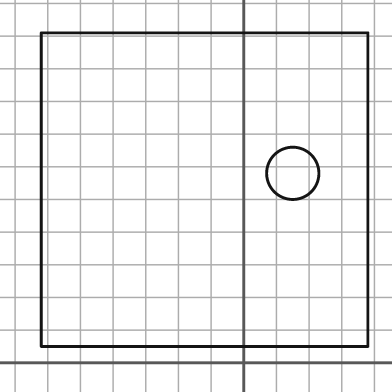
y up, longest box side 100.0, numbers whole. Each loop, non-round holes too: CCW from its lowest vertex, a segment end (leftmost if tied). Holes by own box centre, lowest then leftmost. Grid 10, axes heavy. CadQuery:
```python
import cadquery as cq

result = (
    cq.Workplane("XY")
    .moveTo(-62.0, 5.0)
    .lineTo(38.0, 5.0)
    .lineTo(38.0, 101.0)
    .lineTo(-62.0, 101.0)
    .close()
    .moveTo(15.0, 58.0)
    .circle(8.0)
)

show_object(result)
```